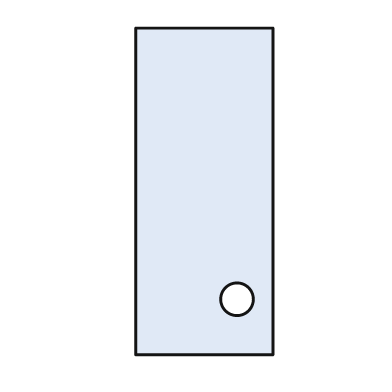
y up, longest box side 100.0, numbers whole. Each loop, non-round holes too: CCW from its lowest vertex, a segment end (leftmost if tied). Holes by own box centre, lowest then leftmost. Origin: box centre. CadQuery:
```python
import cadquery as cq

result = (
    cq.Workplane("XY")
    .moveTo(-21.0, -50.0)
    .lineTo(21.0, -50.0)
    .lineTo(21.0, 50.0)
    .lineTo(-21.0, 50.0)
    .close()
    .moveTo(10.0, -33.0)
    .circle(5.0)
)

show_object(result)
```